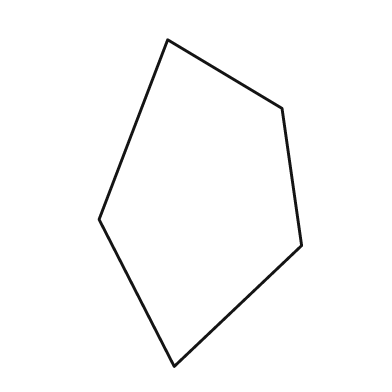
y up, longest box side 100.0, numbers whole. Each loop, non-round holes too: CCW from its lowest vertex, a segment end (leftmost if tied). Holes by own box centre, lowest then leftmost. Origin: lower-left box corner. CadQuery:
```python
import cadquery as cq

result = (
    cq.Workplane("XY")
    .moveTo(23.0, 0.0)
    .lineTo(62.0, 37.0)
    .lineTo(56.0, 79.0)
    .lineTo(21.0, 100.0)
    .lineTo(0.0, 45.0)
    .close()
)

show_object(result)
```